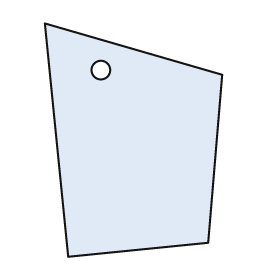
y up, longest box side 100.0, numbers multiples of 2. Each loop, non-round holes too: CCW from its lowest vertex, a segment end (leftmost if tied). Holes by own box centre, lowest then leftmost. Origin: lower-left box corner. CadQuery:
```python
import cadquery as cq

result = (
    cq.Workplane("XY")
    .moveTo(10.0, 0.0)
    .lineTo(70.0, 6.0)
    .lineTo(76.0, 78.0)
    .lineTo(0.0, 100.0)
    .close()
    .moveTo(24.0, 80.0)
    .circle(4.0)
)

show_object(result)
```